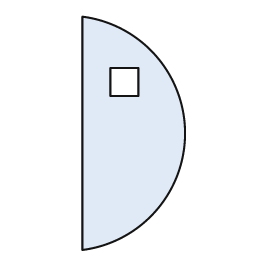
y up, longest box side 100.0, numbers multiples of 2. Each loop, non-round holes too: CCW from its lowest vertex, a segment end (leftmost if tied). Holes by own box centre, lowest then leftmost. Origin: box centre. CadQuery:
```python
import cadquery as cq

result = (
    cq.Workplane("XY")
    .moveTo(-22.0, -50.0)
    .threePointArc((22.0, 0.0), (-22.0, 50.0))
    .close()
    .moveTo(-10.0, 16.0)
    .lineTo(2.0, 16.0)
    .lineTo(2.0, 28.0)
    .lineTo(-10.0, 28.0)
    .close()
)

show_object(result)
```